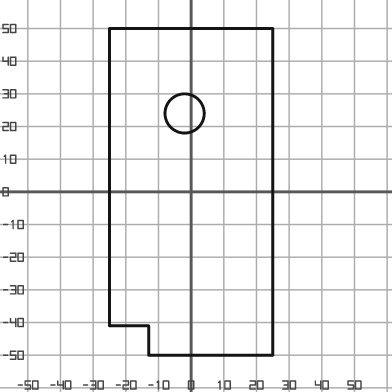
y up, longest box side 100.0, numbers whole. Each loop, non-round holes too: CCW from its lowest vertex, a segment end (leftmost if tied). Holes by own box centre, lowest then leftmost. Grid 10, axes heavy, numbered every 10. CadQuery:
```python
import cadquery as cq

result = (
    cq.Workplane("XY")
    .moveTo(-13.0, -50.0)
    .lineTo(25.0, -50.0)
    .lineTo(25.0, 50.0)
    .lineTo(-25.0, 50.0)
    .lineTo(-25.0, -41.0)
    .lineTo(-13.0, -41.0)
    .close()
    .moveTo(-2.0, 24.0)
    .circle(6.0)
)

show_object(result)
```